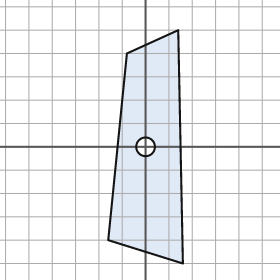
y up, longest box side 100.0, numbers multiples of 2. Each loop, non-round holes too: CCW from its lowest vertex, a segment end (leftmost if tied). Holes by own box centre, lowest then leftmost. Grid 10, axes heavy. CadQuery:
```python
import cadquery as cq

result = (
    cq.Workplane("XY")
    .moveTo(16.0, -50.0)
    .lineTo(14.0, 50.0)
    .lineTo(-8.0, 40.0)
    .lineTo(-16.0, -40.0)
    .close()
    .moveTo(0.0, 0.0)
    .circle(4.0)
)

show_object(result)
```